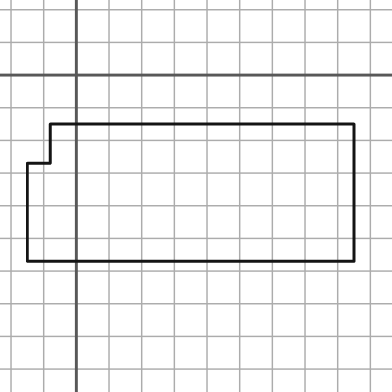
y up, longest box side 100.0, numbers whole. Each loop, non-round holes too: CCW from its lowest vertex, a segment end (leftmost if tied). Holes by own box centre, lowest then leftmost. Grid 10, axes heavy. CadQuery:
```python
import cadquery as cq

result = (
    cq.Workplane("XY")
    .moveTo(-15.0, -57.0)
    .lineTo(85.0, -57.0)
    .lineTo(85.0, -15.0)
    .lineTo(-8.0, -15.0)
    .lineTo(-8.0, -27.0)
    .lineTo(-15.0, -27.0)
    .close()
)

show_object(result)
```